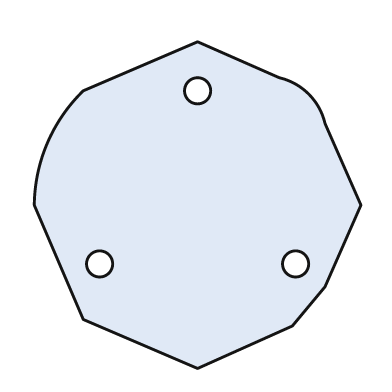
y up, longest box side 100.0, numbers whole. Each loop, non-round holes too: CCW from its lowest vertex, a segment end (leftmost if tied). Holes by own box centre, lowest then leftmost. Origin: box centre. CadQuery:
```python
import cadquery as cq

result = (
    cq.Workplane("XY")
    .moveTo(0.0, -50.0)
    .lineTo(29.0, -37.0)
    .lineTo(39.0, -25.0)
    .lineTo(50.0, 0.0)
    .lineTo(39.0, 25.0)
    .threePointArc((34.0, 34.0), (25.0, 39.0))
    .lineTo(0.0, 50.0)
    .lineTo(-35.0, 35.0)
    .threePointArc((-46.0, 19.0), (-50.0, 0.0))
    .lineTo(-35.0, -35.0)
    .close()
    .moveTo(-30.0, -18.0)
    .circle(4.0)
    .moveTo(30.0, -18.0)
    .circle(4.0)
    .moveTo(0.0, 35.0)
    .circle(4.0)
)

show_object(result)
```